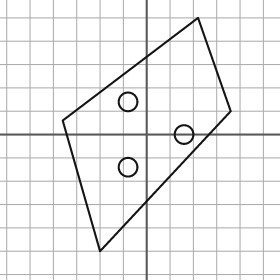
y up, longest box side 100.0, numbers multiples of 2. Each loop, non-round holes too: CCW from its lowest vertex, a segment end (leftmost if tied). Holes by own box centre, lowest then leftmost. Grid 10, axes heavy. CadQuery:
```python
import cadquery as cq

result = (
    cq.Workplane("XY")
    .moveTo(-20.0, -50.0)
    .lineTo(36.0, 10.0)
    .lineTo(22.0, 50.0)
    .lineTo(-36.0, 6.0)
    .close()
    .moveTo(-8.0, -14.0)
    .circle(4.0)
    .moveTo(16.0, 0.0)
    .circle(4.0)
    .moveTo(-8.0, 14.0)
    .circle(4.0)
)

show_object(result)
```